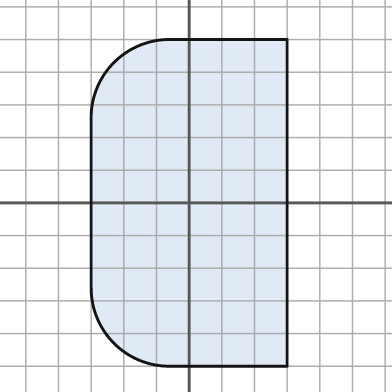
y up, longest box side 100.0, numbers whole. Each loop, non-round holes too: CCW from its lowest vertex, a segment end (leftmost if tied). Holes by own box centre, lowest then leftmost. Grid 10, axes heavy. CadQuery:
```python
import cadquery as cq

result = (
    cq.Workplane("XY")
    .moveTo(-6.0, -50.0)
    .lineTo(30.0, -50.0)
    .lineTo(30.0, 50.0)
    .lineTo(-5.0, 50.0)
    .threePointArc((-23.0, 43.0), (-30.0, 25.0))
    .lineTo(-30.0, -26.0)
    .threePointArc((-23.0, -43.0), (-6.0, -50.0))
    .close()
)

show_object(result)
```